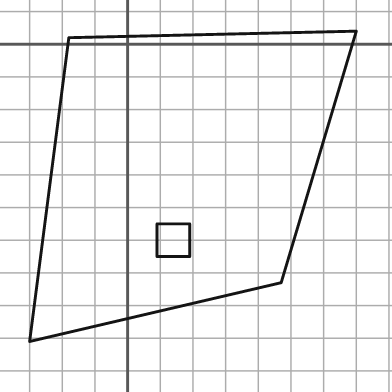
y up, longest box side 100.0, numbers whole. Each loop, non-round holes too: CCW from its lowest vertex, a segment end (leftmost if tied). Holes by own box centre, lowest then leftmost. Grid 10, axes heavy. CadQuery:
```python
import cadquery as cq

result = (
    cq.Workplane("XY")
    .moveTo(-30.0, -91.0)
    .lineTo(47.0, -73.0)
    .lineTo(70.0, 4.0)
    .lineTo(-18.0, 2.0)
    .close()
    .moveTo(9.0, -65.0)
    .lineTo(19.0, -65.0)
    .lineTo(19.0, -55.0)
    .lineTo(9.0, -55.0)
    .close()
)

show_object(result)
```